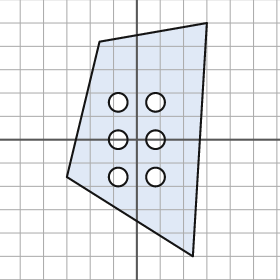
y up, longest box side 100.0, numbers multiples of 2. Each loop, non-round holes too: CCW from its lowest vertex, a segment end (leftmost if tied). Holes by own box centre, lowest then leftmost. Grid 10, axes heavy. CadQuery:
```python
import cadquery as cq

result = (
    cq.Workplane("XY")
    .moveTo(24.0, -50.0)
    .lineTo(30.0, 50.0)
    .lineTo(-16.0, 42.0)
    .lineTo(-30.0, -16.0)
    .close()
    .moveTo(-8.0, -16.0)
    .circle(4.0)
    .moveTo(8.0, -16.0)
    .circle(4.0)
    .moveTo(-8.0, 0.0)
    .circle(4.0)
    .moveTo(8.0, 0.0)
    .circle(4.0)
    .moveTo(-8.0, 16.0)
    .circle(4.0)
    .moveTo(8.0, 16.0)
    .circle(4.0)
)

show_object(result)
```